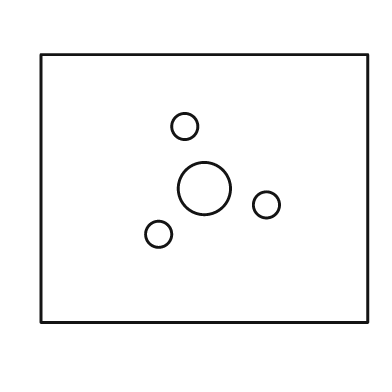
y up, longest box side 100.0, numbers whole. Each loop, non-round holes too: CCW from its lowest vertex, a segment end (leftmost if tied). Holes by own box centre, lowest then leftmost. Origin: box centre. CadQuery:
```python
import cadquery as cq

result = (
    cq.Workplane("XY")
    .moveTo(-50.0, -41.0)
    .lineTo(50.0, -41.0)
    .lineTo(50.0, 41.0)
    .lineTo(-50.0, 41.0)
    .close()
    .moveTo(-14.0, -14.0)
    .circle(4.0)
    .moveTo(19.0, -5.0)
    .circle(4.0)
    .moveTo(0.0, 0.0)
    .circle(8.0)
    .moveTo(-6.0, 19.0)
    .circle(4.0)
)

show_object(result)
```